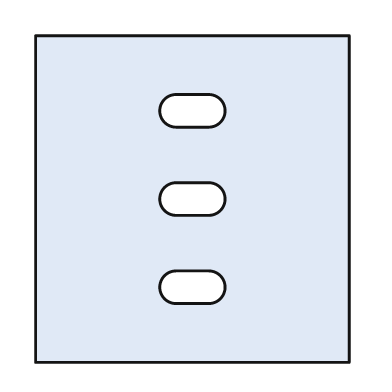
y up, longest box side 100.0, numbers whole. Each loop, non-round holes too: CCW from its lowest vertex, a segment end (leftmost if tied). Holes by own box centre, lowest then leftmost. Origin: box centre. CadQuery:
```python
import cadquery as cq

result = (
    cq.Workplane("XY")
    .moveTo(-48.0, -50.0)
    .lineTo(48.0, -50.0)
    .lineTo(48.0, 50.0)
    .lineTo(-48.0, 50.0)
    .close()
    .moveTo(-5.0, -32.0)
    .lineTo(5.0, -32.0)
    .threePointArc((10.0, -27.0), (5.0, -22.0))
    .lineTo(-5.0, -22.0)
    .threePointArc((-10.0, -27.0), (-5.0, -32.0))
    .close()
    .moveTo(-5.0, -5.0)
    .lineTo(5.0, -5.0)
    .threePointArc((10.0, 0.0), (5.0, 5.0))
    .lineTo(-5.0, 5.0)
    .threePointArc((-10.0, 0.0), (-5.0, -5.0))
    .close()
    .moveTo(-5.0, 22.0)
    .lineTo(5.0, 22.0)
    .threePointArc((10.0, 27.0), (5.0, 32.0))
    .lineTo(-5.0, 32.0)
    .threePointArc((-10.0, 27.0), (-5.0, 22.0))
    .close()
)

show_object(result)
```